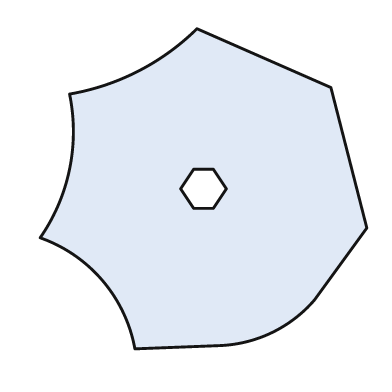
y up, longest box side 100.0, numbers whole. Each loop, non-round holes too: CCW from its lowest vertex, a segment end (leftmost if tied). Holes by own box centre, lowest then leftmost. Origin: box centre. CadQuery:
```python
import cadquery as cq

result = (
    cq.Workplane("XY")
    .moveTo(-21.0, -49.0)
    .lineTo(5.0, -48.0)
    .threePointArc((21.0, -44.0), (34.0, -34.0))
    .lineTo(50.0, -12.0)
    .lineTo(39.0, 31.0)
    .lineTo(-2.0, 49.0)
    .threePointArc((-20.0, 36.0), (-41.0, 29.0))
    .threePointArc((-41.0, 6.0), (-50.0, -15.0))
    .threePointArc((-31.0, -28.0), (-21.0, -49.0))
    .close()
    .moveTo(-3.0, -6.0)
    .lineTo(3.0, -6.0)
    .lineTo(7.0, 0.0)
    .lineTo(3.0, 6.0)
    .lineTo(-3.0, 6.0)
    .lineTo(-7.0, 0.0)
    .close()
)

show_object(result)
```